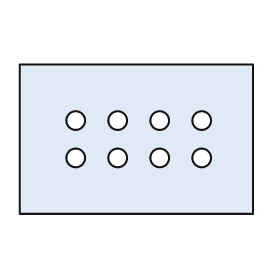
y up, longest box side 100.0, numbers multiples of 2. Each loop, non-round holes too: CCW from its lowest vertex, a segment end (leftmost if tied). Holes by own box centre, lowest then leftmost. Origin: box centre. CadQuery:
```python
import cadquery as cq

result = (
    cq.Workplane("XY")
    .moveTo(-50.0, -32.0)
    .lineTo(50.0, -32.0)
    .lineTo(50.0, 32.0)
    .lineTo(-50.0, 32.0)
    .close()
    .moveTo(-26.0, -8.0)
    .circle(4.0)
    .moveTo(-8.0, -8.0)
    .circle(4.0)
    .moveTo(10.0, -8.0)
    .circle(4.0)
    .moveTo(28.0, -8.0)
    .circle(4.0)
    .moveTo(-26.0, 8.0)
    .circle(4.0)
    .moveTo(-8.0, 8.0)
    .circle(4.0)
    .moveTo(10.0, 8.0)
    .circle(4.0)
    .moveTo(28.0, 8.0)
    .circle(4.0)
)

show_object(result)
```